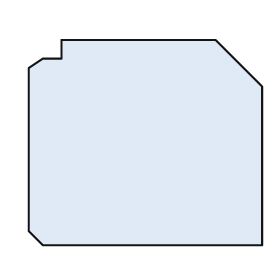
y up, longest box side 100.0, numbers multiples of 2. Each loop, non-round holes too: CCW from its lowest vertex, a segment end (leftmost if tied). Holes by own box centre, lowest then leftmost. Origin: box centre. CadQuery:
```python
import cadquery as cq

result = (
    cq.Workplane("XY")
    .moveTo(-44.0, -44.0)
    .lineTo(50.0, -44.0)
    .lineTo(50.0, 24.0)
    .lineTo(30.0, 44.0)
    .lineTo(-36.0, 44.0)
    .lineTo(-36.0, 36.0)
    .lineTo(-44.0, 36.0)
    .lineTo(-50.0, 32.0)
    .lineTo(-50.0, -38.0)
    .close()
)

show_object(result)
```